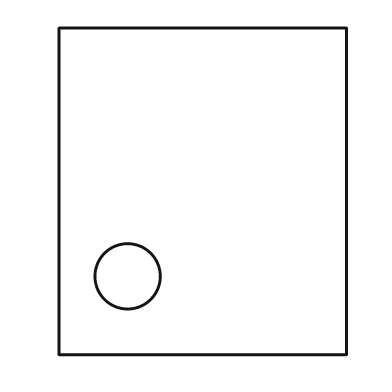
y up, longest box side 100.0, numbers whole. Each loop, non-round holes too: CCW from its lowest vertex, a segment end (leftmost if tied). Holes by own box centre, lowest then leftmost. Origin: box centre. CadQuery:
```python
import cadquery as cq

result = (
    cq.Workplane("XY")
    .moveTo(-44.0, -50.0)
    .lineTo(44.0, -50.0)
    .lineTo(44.0, 50.0)
    .lineTo(-44.0, 50.0)
    .close()
    .moveTo(-23.0, -26.0)
    .circle(10.0)
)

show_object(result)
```